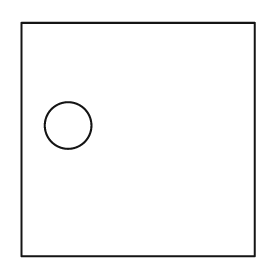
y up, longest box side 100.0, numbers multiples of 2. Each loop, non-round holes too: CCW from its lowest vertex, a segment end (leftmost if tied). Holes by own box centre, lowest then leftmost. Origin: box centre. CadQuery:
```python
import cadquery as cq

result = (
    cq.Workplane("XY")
    .moveTo(-50.0, -50.0)
    .lineTo(50.0, -50.0)
    .lineTo(50.0, 50.0)
    .lineTo(-50.0, 50.0)
    .close()
    .moveTo(-30.0, 6.0)
    .circle(10.0)
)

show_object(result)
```